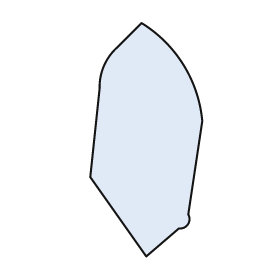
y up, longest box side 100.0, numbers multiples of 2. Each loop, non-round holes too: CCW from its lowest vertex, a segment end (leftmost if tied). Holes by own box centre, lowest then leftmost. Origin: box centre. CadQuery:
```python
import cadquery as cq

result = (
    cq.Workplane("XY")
    .moveTo(0.0, -50.0)
    .lineTo(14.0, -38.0)
    .threePointArc((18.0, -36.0), (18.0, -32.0))
    .lineTo(24.0, 8.0)
    .threePointArc((16.0, 32.0), (-2.0, 50.0))
    .lineTo(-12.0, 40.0)
    .threePointArc((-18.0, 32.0), (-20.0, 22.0))
    .lineTo(-24.0, -16.0)
    .close()
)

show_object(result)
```